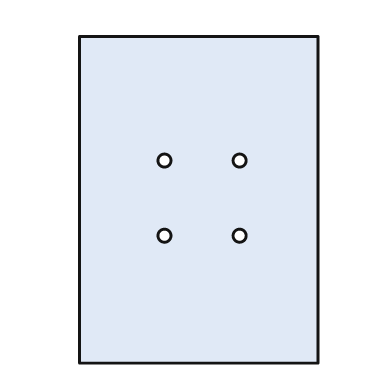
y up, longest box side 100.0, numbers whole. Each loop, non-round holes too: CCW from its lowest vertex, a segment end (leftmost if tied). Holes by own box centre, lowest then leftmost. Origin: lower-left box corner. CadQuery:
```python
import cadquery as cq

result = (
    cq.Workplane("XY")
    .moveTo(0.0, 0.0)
    .lineTo(73.0, 0.0)
    .lineTo(73.0, 100.0)
    .lineTo(0.0, 100.0)
    .close()
    .moveTo(26.0, 39.0)
    .circle(2.0)
    .moveTo(49.0, 39.0)
    .circle(2.0)
    .moveTo(26.0, 62.0)
    .circle(2.0)
    .moveTo(49.0, 62.0)
    .circle(2.0)
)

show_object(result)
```